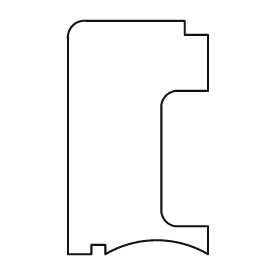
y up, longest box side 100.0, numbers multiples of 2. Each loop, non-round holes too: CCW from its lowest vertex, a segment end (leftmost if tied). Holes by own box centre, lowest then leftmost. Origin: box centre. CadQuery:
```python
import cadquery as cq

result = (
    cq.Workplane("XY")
    .moveTo(-30.0, -50.0)
    .lineTo(-20.0, -50.0)
    .lineTo(-20.0, -46.0)
    .lineTo(-14.0, -46.0)
    .lineTo(-14.0, -50.0)
    .threePointArc((8.0, -44.0), (30.0, -50.0))
    .lineTo(30.0, -38.0)
    .lineTo(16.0, -38.0)
    .threePointArc((12.0, -36.0), (10.0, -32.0))
    .lineTo(10.0, 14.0)
    .threePointArc((12.0, 18.0), (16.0, 20.0))
    .lineTo(30.0, 20.0)
    .lineTo(30.0, 44.0)
    .lineTo(20.0, 44.0)
    .lineTo(20.0, 50.0)
    .lineTo(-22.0, 50.0)
    .threePointArc((-28.0, 48.0), (-30.0, 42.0))
    .close()
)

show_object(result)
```